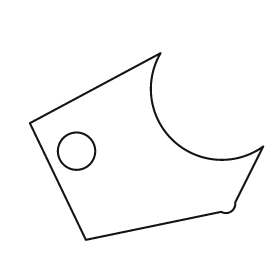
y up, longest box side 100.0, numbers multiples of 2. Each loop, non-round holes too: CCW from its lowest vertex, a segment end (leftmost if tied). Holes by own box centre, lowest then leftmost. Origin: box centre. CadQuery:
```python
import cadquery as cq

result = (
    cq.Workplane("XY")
    .moveTo(-26.0, -40.0)
    .lineTo(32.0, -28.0)
    .threePointArc((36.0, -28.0), (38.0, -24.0))
    .lineTo(50.0, 0.0)
    .threePointArc((12.0, 2.0), (6.0, 40.0))
    .lineTo(-50.0, 10.0)
    .close()
    .moveTo(-30.0, -2.0)
    .circle(8.0)
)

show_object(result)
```